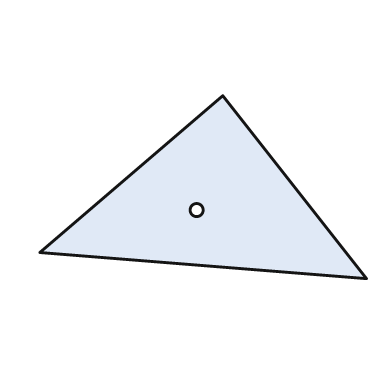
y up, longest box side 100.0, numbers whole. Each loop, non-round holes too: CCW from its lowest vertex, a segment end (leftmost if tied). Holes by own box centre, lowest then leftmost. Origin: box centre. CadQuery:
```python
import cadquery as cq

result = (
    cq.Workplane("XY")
    .moveTo(50.0, -28.0)
    .lineTo(6.0, 28.0)
    .lineTo(-50.0, -20.0)
    .close()
    .moveTo(-2.0, -7.0)
    .circle(2.0)
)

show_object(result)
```